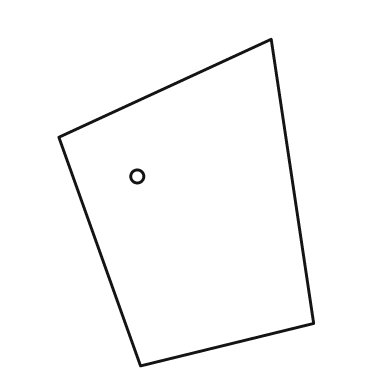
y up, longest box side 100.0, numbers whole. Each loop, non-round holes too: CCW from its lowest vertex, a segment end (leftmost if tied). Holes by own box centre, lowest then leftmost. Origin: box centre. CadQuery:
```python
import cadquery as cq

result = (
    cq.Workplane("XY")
    .moveTo(-14.0, -50.0)
    .lineTo(39.0, -37.0)
    .lineTo(26.0, 50.0)
    .lineTo(-39.0, 20.0)
    .close()
    .moveTo(-15.0, 8.0)
    .circle(2.0)
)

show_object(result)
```